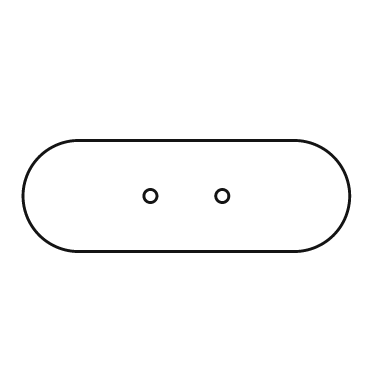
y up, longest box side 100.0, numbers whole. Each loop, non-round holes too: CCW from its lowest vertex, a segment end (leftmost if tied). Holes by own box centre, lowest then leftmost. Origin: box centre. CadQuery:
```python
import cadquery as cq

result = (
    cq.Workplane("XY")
    .moveTo(-33.0, -17.0)
    .lineTo(33.0, -17.0)
    .threePointArc((50.0, 0.0), (33.0, 17.0))
    .lineTo(-33.0, 17.0)
    .threePointArc((-50.0, 0.0), (-33.0, -17.0))
    .close()
    .moveTo(-11.0, 0.0)
    .circle(2.0)
    .moveTo(11.0, 0.0)
    .circle(2.0)
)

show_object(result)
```